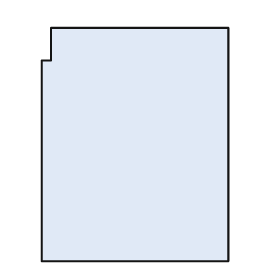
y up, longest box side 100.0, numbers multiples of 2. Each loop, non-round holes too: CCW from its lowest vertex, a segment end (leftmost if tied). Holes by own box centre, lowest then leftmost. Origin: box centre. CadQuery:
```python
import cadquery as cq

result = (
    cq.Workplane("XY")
    .moveTo(-40.0, -50.0)
    .lineTo(40.0, -50.0)
    .lineTo(40.0, 50.0)
    .lineTo(-36.0, 50.0)
    .lineTo(-36.0, 36.0)
    .lineTo(-40.0, 36.0)
    .close()
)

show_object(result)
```